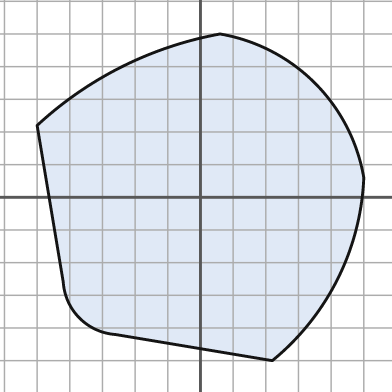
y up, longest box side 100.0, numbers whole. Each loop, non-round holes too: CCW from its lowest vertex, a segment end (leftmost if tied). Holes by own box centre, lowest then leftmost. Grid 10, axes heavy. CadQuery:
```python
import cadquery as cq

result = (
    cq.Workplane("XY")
    .moveTo(22.0, -50.0)
    .threePointArc((42.0, -25.0), (50.0, 6.0))
    .threePointArc((35.0, 35.0), (6.0, 50.0))
    .threePointArc((-24.0, 40.0), (-50.0, 22.0))
    .lineTo(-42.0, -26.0)
    .threePointArc((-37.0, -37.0), (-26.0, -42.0))
    .close()
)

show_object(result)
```